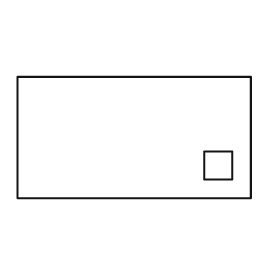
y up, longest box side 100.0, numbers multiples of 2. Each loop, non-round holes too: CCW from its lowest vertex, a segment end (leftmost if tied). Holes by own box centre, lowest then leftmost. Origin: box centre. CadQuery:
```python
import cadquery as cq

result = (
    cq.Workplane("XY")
    .moveTo(-50.0, -26.0)
    .lineTo(50.0, -26.0)
    .lineTo(50.0, 26.0)
    .lineTo(-50.0, 26.0)
    .close()
    .moveTo(30.0, -18.0)
    .lineTo(42.0, -18.0)
    .lineTo(42.0, -6.0)
    .lineTo(30.0, -6.0)
    .close()
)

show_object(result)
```